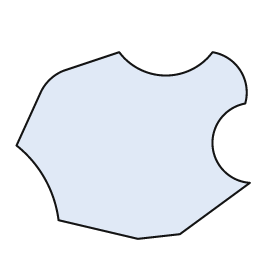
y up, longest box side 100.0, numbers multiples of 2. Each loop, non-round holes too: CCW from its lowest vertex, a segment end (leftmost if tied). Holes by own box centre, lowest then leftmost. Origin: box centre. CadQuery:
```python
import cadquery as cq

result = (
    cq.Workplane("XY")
    .moveTo(2.0, -40.0)
    .lineTo(20.0, -38.0)
    .lineTo(50.0, -16.0)
    .threePointArc((34.0, 0.0), (48.0, 18.0))
    .threePointArc((46.0, 32.0), (34.0, 40.0))
    .threePointArc((14.0, 30.0), (-6.0, 40.0))
    .lineTo(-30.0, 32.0)
    .threePointArc((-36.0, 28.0), (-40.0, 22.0))
    .lineTo(-50.0, 0.0)
    .threePointArc((-38.0, -14.0), (-32.0, -32.0))
    .close()
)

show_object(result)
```